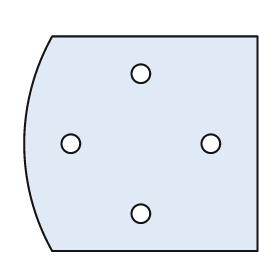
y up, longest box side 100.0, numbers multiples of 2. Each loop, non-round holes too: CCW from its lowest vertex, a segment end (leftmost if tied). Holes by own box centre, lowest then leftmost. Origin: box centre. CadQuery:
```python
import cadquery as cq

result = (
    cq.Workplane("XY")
    .moveTo(-38.0, -46.0)
    .lineTo(50.0, -46.0)
    .lineTo(50.0, 46.0)
    .lineTo(-38.0, 46.0)
    .threePointArc((-50.0, 0.0), (-38.0, -46.0))
    .close()
    .moveTo(0.0, -30.0)
    .circle(4.0)
    .moveTo(-30.0, 0.0)
    .circle(4.0)
    .moveTo(30.0, 0.0)
    .circle(4.0)
    .moveTo(0.0, 30.0)
    .circle(4.0)
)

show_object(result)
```